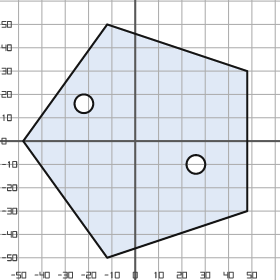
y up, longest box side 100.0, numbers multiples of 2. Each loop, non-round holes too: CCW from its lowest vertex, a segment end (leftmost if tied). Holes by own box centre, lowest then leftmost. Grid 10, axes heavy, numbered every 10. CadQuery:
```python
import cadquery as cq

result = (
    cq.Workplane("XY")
    .moveTo(-12.0, -50.0)
    .lineTo(48.0, -30.0)
    .lineTo(48.0, 30.0)
    .lineTo(-12.0, 50.0)
    .lineTo(-48.0, 0.0)
    .close()
    .moveTo(26.0, -10.0)
    .circle(4.0)
    .moveTo(-22.0, 16.0)
    .circle(4.0)
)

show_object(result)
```